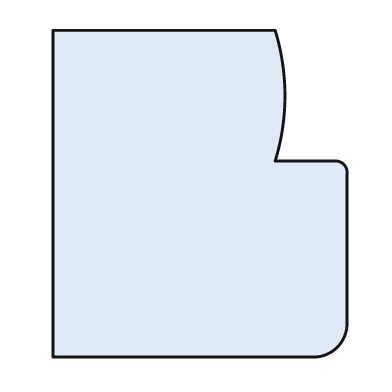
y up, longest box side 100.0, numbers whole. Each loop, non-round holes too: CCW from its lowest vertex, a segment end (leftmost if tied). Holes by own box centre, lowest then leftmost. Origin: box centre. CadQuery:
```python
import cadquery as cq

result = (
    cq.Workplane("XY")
    .moveTo(-45.0, -50.0)
    .lineTo(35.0, -50.0)
    .threePointArc((42.0, -47.0), (45.0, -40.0))
    .lineTo(45.0, 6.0)
    .threePointArc((44.0, 9.0), (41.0, 10.0))
    .lineTo(23.0, 10.0)
    .threePointArc((26.0, 30.0), (23.0, 50.0))
    .lineTo(-45.0, 50.0)
    .close()
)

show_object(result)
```